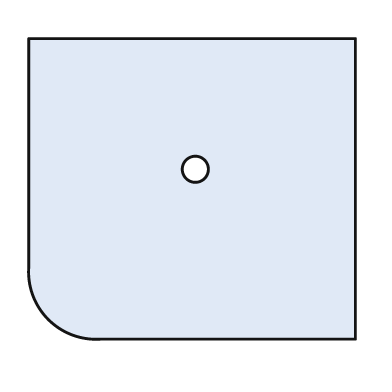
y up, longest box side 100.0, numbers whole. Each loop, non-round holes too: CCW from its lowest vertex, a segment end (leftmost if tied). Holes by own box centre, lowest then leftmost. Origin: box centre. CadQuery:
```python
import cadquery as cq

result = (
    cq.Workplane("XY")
    .moveTo(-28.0, -46.0)
    .lineTo(50.0, -46.0)
    .lineTo(50.0, 46.0)
    .lineTo(-50.0, 46.0)
    .lineTo(-50.0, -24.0)
    .threePointArc((-44.0, -40.0), (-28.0, -46.0))
    .close()
    .moveTo(1.0, 6.0)
    .circle(4.0)
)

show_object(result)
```